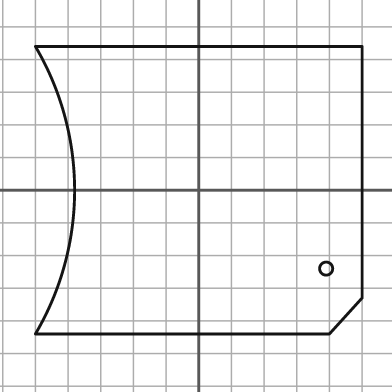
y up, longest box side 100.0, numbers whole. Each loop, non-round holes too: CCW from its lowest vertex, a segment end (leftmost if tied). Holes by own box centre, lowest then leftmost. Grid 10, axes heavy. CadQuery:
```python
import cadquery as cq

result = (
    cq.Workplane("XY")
    .moveTo(-50.0, -44.0)
    .lineTo(40.0, -44.0)
    .lineTo(50.0, -33.0)
    .lineTo(50.0, 44.0)
    .lineTo(-50.0, 44.0)
    .threePointArc((-38.0, 0.0), (-50.0, -44.0))
    .close()
    .moveTo(39.0, -24.0)
    .circle(2.0)
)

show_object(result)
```